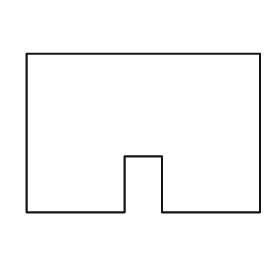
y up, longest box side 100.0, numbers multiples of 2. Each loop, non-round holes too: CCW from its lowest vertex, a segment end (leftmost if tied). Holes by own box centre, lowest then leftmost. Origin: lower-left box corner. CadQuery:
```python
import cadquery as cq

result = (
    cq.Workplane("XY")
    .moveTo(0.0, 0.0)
    .lineTo(42.0, 0.0)
    .lineTo(42.0, 24.0)
    .lineTo(58.0, 24.0)
    .lineTo(58.0, 0.0)
    .lineTo(100.0, 0.0)
    .lineTo(100.0, 68.0)
    .lineTo(0.0, 68.0)
    .close()
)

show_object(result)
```